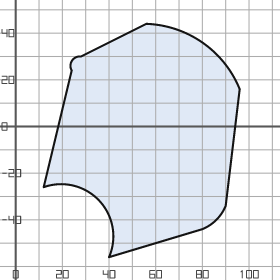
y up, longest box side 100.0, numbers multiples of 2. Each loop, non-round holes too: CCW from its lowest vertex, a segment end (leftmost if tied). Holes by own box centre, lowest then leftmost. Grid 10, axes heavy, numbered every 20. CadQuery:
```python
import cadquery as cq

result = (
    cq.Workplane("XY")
    .moveTo(40.0, -56.0)
    .lineTo(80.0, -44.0)
    .threePointArc((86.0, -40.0), (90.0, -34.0))
    .lineTo(96.0, 16.0)
    .threePointArc((80.0, 36.0), (56.0, 44.0))
    .lineTo(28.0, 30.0)
    .threePointArc((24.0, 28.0), (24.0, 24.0))
    .lineTo(12.0, -26.0)
    .threePointArc((36.0, -32.0), (40.0, -56.0))
    .close()
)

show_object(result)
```